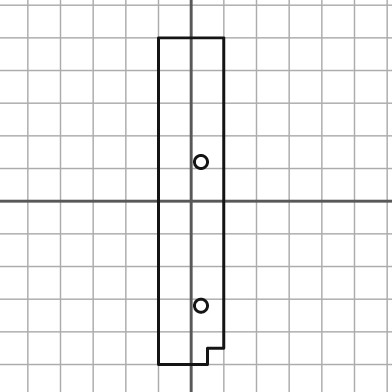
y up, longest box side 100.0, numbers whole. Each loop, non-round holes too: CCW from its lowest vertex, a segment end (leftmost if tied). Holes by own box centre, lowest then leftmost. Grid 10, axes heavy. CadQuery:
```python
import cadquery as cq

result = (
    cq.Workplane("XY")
    .moveTo(-10.0, -50.0)
    .lineTo(5.0, -50.0)
    .lineTo(5.0, -45.0)
    .lineTo(10.0, -45.0)
    .lineTo(10.0, 50.0)
    .lineTo(-10.0, 50.0)
    .close()
    .moveTo(3.0, -32.0)
    .circle(2.0)
    .moveTo(3.0, 12.0)
    .circle(2.0)
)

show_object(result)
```